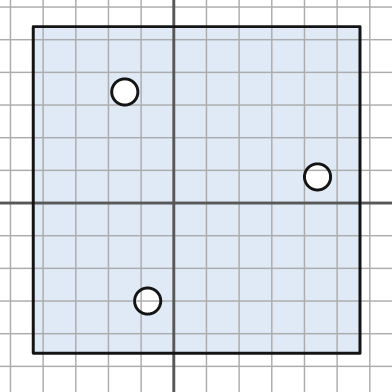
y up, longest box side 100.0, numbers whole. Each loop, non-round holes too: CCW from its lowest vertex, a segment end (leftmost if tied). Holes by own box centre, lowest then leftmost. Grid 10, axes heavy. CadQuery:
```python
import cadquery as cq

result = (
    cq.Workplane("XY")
    .moveTo(-43.0, -46.0)
    .lineTo(57.0, -46.0)
    .lineTo(57.0, 54.0)
    .lineTo(-43.0, 54.0)
    .close()
    .moveTo(-8.0, -30.0)
    .circle(4.0)
    .moveTo(44.0, 8.0)
    .circle(4.0)
    .moveTo(-15.0, 34.0)
    .circle(4.0)
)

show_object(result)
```